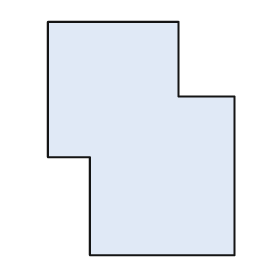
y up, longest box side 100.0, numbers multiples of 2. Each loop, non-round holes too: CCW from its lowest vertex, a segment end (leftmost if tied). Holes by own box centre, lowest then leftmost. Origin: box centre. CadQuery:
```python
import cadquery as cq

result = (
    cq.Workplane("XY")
    .moveTo(-22.0, -50.0)
    .lineTo(40.0, -50.0)
    .lineTo(40.0, 18.0)
    .lineTo(16.0, 18.0)
    .lineTo(16.0, 50.0)
    .lineTo(-40.0, 50.0)
    .lineTo(-40.0, -8.0)
    .lineTo(-22.0, -8.0)
    .close()
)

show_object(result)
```